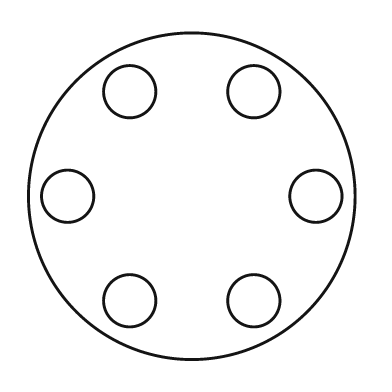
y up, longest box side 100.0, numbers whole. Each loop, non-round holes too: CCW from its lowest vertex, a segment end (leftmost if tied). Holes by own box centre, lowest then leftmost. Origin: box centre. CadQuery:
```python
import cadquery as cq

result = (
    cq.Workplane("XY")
    .moveTo(0.0, 0.0)
    .circle(50.0)
    .moveTo(-19.0, -32.0)
    .circle(8.0)
    .moveTo(19.0, -32.0)
    .circle(8.0)
    .moveTo(-38.0, 0.0)
    .circle(8.0)
    .moveTo(38.0, 0.0)
    .circle(8.0)
    .moveTo(-19.0, 32.0)
    .circle(8.0)
    .moveTo(19.0, 32.0)
    .circle(8.0)
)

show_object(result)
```